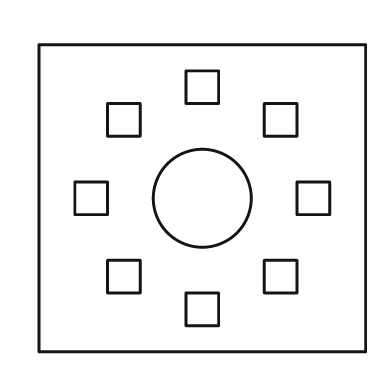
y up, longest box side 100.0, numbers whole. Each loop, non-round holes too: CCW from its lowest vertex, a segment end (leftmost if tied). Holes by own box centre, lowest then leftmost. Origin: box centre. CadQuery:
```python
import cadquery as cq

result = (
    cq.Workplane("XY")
    .moveTo(-50.0, -47.0)
    .lineTo(50.0, -47.0)
    .lineTo(50.0, 47.0)
    .lineTo(-50.0, 47.0)
    .close()
    .moveTo(-5.0, -39.0)
    .lineTo(5.0, -39.0)
    .lineTo(5.0, -29.0)
    .lineTo(-5.0, -29.0)
    .close()
    .moveTo(-29.0, -29.0)
    .lineTo(-19.0, -29.0)
    .lineTo(-19.0, -19.0)
    .lineTo(-29.0, -19.0)
    .close()
    .moveTo(19.0, -29.0)
    .lineTo(29.0, -29.0)
    .lineTo(29.0, -19.0)
    .lineTo(19.0, -19.0)
    .close()
    .moveTo(-39.0, -5.0)
    .lineTo(-29.0, -5.0)
    .lineTo(-29.0, 5.0)
    .lineTo(-39.0, 5.0)
    .close()
    .moveTo(0.0, 0.0)
    .circle(15.0)
    .moveTo(29.0, -5.0)
    .lineTo(39.0, -5.0)
    .lineTo(39.0, 5.0)
    .lineTo(29.0, 5.0)
    .close()
    .moveTo(-29.0, 19.0)
    .lineTo(-19.0, 19.0)
    .lineTo(-19.0, 29.0)
    .lineTo(-29.0, 29.0)
    .close()
    .moveTo(19.0, 19.0)
    .lineTo(29.0, 19.0)
    .lineTo(29.0, 29.0)
    .lineTo(19.0, 29.0)
    .close()
    .moveTo(-5.0, 29.0)
    .lineTo(5.0, 29.0)
    .lineTo(5.0, 39.0)
    .lineTo(-5.0, 39.0)
    .close()
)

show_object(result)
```